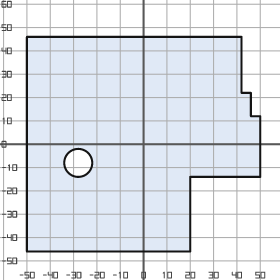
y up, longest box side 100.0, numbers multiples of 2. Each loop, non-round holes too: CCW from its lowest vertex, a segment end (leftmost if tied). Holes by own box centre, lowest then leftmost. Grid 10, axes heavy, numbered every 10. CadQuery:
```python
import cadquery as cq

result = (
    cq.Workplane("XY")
    .moveTo(-50.0, -46.0)
    .lineTo(20.0, -46.0)
    .lineTo(20.0, -14.0)
    .lineTo(50.0, -14.0)
    .lineTo(50.0, 12.0)
    .lineTo(46.0, 12.0)
    .lineTo(46.0, 22.0)
    .lineTo(42.0, 22.0)
    .lineTo(42.0, 46.0)
    .lineTo(-50.0, 46.0)
    .close()
    .moveTo(-28.0, -8.0)
    .circle(6.0)
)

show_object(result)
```